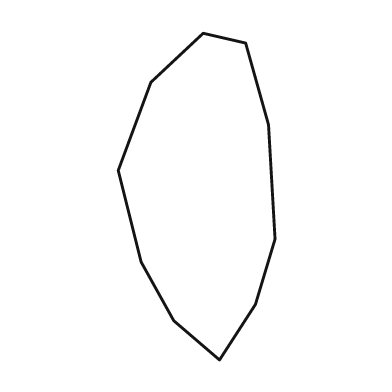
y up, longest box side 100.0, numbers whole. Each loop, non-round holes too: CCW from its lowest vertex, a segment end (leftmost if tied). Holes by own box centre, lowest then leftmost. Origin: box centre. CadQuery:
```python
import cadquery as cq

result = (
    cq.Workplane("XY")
    .moveTo(7.0, -50.0)
    .lineTo(18.0, -33.0)
    .lineTo(24.0, -13.0)
    .lineTo(22.0, 22.0)
    .lineTo(15.0, 47.0)
    .lineTo(2.0, 50.0)
    .lineTo(-14.0, 35.0)
    .lineTo(-24.0, 8.0)
    .lineTo(-17.0, -20.0)
    .lineTo(-7.0, -38.0)
    .close()
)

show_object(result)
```